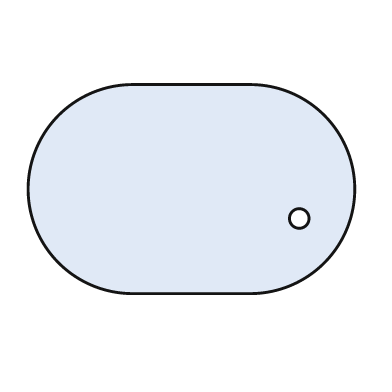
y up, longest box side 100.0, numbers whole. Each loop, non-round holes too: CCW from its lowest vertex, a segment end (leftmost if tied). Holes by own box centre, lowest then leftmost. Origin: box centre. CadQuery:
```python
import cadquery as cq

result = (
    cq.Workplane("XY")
    .moveTo(-18.0, -32.0)
    .lineTo(18.0, -32.0)
    .threePointArc((50.0, 0.0), (18.0, 32.0))
    .lineTo(-18.0, 32.0)
    .threePointArc((-50.0, 0.0), (-18.0, -32.0))
    .close()
    .moveTo(33.0, -9.0)
    .circle(3.0)
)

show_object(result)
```